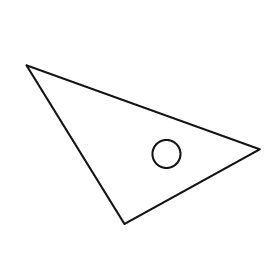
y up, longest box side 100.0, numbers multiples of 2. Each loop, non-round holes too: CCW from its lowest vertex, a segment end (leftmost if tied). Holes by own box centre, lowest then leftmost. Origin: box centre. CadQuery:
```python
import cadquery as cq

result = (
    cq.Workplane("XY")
    .moveTo(-8.0, -34.0)
    .lineTo(50.0, -2.0)
    .lineTo(-50.0, 34.0)
    .close()
    .moveTo(10.0, -4.0)
    .circle(6.0)
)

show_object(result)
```